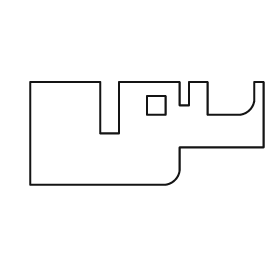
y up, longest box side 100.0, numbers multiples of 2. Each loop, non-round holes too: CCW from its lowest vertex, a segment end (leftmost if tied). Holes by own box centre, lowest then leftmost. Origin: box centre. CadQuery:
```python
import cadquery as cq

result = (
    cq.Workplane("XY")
    .moveTo(-50.0, -22.0)
    .lineTo(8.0, -22.0)
    .threePointArc((12.0, -20.0), (14.0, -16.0))
    .lineTo(14.0, -6.0)
    .lineTo(50.0, -6.0)
    .lineTo(50.0, 22.0)
    .lineTo(46.0, 22.0)
    .lineTo(46.0, 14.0)
    .threePointArc((44.0, 10.0), (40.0, 8.0))
    .lineTo(26.0, 8.0)
    .lineTo(26.0, 22.0)
    .lineTo(18.0, 22.0)
    .lineTo(18.0, 12.0)
    .lineTo(14.0, 12.0)
    .lineTo(14.0, 22.0)
    .lineTo(-12.0, 22.0)
    .lineTo(-12.0, 0.0)
    .lineTo(-20.0, 0.0)
    .lineTo(-20.0, 22.0)
    .lineTo(-50.0, 22.0)
    .close()
    .moveTo(0.0, 8.0)
    .lineTo(8.0, 8.0)
    .lineTo(8.0, 16.0)
    .lineTo(0.0, 16.0)
    .close()
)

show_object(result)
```